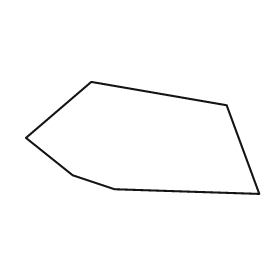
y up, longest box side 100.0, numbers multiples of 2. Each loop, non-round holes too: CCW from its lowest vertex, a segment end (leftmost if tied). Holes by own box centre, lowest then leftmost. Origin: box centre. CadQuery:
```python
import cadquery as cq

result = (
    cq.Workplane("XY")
    .moveTo(50.0, -24.0)
    .lineTo(36.0, 14.0)
    .lineTo(-22.0, 24.0)
    .lineTo(-50.0, 0.0)
    .lineTo(-30.0, -16.0)
    .lineTo(-12.0, -22.0)
    .close()
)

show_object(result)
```